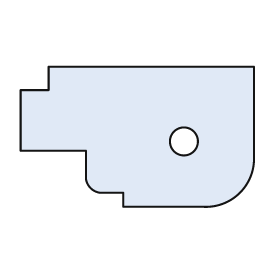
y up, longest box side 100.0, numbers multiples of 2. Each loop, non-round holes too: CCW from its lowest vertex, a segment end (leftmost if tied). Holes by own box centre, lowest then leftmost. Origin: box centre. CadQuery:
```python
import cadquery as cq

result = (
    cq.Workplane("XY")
    .moveTo(-6.0, -30.0)
    .lineTo(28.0, -30.0)
    .threePointArc((44.0, -24.0), (50.0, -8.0))
    .lineTo(50.0, 30.0)
    .lineTo(-38.0, 30.0)
    .lineTo(-38.0, 20.0)
    .lineTo(-50.0, 20.0)
    .lineTo(-50.0, -6.0)
    .lineTo(-22.0, -6.0)
    .lineTo(-22.0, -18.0)
    .threePointArc((-20.0, -22.0), (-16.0, -24.0))
    .lineTo(-6.0, -24.0)
    .close()
    .moveTo(20.0, -2.0)
    .circle(6.0)
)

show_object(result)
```